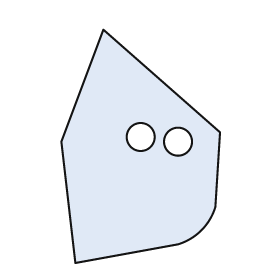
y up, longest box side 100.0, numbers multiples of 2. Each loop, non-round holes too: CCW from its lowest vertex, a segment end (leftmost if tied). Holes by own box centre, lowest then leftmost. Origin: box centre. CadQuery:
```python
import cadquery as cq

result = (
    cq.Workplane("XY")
    .moveTo(-28.0, -50.0)
    .lineTo(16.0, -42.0)
    .threePointArc((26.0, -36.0), (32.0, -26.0))
    .lineTo(34.0, 6.0)
    .lineTo(-16.0, 50.0)
    .lineTo(-34.0, 2.0)
    .close()
    .moveTo(16.0, 2.0)
    .circle(6.0)
    .moveTo(0.0, 4.0)
    .circle(6.0)
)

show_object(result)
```